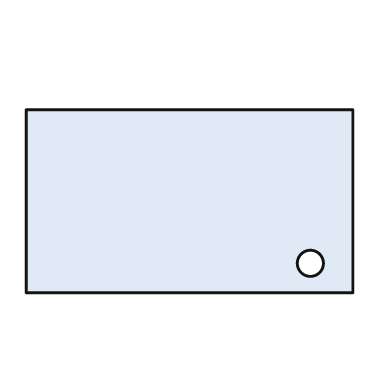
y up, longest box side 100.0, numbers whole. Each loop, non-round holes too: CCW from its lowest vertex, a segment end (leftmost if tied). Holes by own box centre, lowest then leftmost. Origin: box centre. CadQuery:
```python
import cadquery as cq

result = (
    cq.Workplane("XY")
    .moveTo(-50.0, -28.0)
    .lineTo(50.0, -28.0)
    .lineTo(50.0, 28.0)
    .lineTo(-50.0, 28.0)
    .close()
    .moveTo(37.0, -19.0)
    .circle(4.0)
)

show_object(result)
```